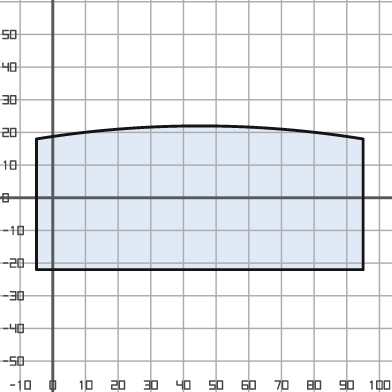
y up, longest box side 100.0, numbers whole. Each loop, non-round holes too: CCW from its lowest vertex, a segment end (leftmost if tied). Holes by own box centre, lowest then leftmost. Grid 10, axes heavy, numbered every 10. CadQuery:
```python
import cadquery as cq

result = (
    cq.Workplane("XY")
    .moveTo(-5.0, -22.0)
    .lineTo(95.0, -22.0)
    .lineTo(95.0, 18.0)
    .threePointArc((45.0, 22.0), (-5.0, 18.0))
    .close()
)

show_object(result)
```